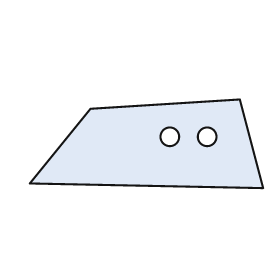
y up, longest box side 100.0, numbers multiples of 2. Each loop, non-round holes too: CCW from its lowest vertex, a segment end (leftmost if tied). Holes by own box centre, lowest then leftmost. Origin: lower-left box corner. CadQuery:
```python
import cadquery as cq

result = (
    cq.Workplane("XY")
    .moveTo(100.0, 0.0)
    .lineTo(90.0, 38.0)
    .lineTo(26.0, 34.0)
    .lineTo(0.0, 2.0)
    .close()
    .moveTo(60.0, 22.0)
    .circle(4.0)
    .moveTo(76.0, 22.0)
    .circle(4.0)
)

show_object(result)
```